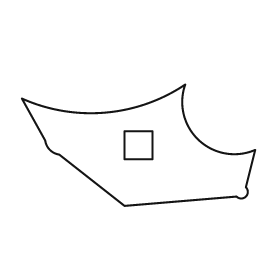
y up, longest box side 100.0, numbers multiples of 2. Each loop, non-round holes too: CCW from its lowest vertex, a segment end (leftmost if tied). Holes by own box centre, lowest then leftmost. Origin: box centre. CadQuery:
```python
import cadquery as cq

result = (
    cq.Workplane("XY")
    .moveTo(-6.0, -26.0)
    .lineTo(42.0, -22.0)
    .threePointArc((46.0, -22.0), (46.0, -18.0))
    .lineTo(50.0, -2.0)
    .threePointArc((26.0, 2.0), (20.0, 26.0))
    .threePointArc((-14.0, 14.0), (-50.0, 20.0))
    .lineTo(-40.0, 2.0)
    .threePointArc((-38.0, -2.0), (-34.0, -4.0))
    .close()
    .moveTo(-6.0, -6.0)
    .lineTo(6.0, -6.0)
    .lineTo(6.0, 6.0)
    .lineTo(-6.0, 6.0)
    .close()
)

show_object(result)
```